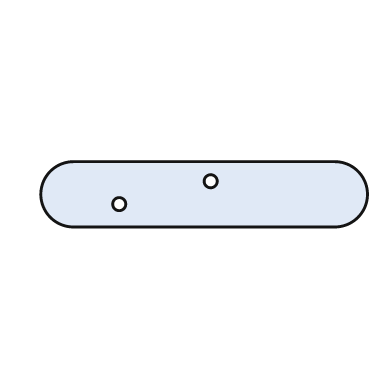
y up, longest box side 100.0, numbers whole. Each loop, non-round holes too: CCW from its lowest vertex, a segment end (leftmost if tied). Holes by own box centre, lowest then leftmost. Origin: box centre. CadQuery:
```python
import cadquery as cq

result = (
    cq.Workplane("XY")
    .moveTo(-40.0, -10.0)
    .lineTo(40.0, -10.0)
    .threePointArc((50.0, 0.0), (40.0, 10.0))
    .lineTo(-40.0, 10.0)
    .threePointArc((-50.0, 0.0), (-40.0, -10.0))
    .close()
    .moveTo(-26.0, -3.0)
    .circle(2.0)
    .moveTo(2.0, 4.0)
    .circle(2.0)
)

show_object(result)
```